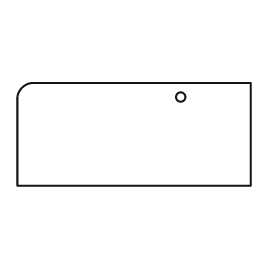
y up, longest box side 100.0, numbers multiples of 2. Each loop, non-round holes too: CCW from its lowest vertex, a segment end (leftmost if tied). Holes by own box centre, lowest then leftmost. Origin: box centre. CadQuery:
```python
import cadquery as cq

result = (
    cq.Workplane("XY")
    .moveTo(-50.0, -22.0)
    .lineTo(50.0, -22.0)
    .lineTo(50.0, 22.0)
    .lineTo(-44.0, 22.0)
    .threePointArc((-48.0, 20.0), (-50.0, 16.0))
    .close()
    .moveTo(20.0, 16.0)
    .circle(2.0)
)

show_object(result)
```